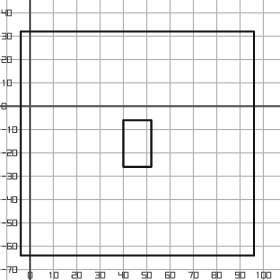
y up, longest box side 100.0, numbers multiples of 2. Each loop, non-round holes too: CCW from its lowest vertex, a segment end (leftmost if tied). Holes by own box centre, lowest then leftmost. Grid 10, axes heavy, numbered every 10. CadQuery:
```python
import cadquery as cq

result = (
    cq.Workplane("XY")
    .moveTo(-4.0, -64.0)
    .lineTo(96.0, -64.0)
    .lineTo(96.0, 32.0)
    .lineTo(-4.0, 32.0)
    .close()
    .moveTo(40.0, -26.0)
    .lineTo(52.0, -26.0)
    .lineTo(52.0, -6.0)
    .lineTo(40.0, -6.0)
    .close()
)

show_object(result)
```